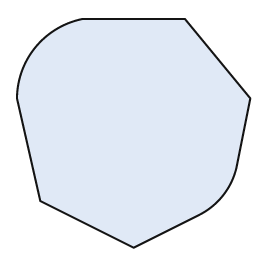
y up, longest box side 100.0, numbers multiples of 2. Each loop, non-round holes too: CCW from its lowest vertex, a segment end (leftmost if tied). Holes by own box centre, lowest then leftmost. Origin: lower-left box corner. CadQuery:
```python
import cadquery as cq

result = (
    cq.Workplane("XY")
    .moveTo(50.0, 0.0)
    .lineTo(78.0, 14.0)
    .threePointArc((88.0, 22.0), (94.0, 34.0))
    .lineTo(100.0, 64.0)
    .lineTo(72.0, 98.0)
    .lineTo(28.0, 98.0)
    .threePointArc((8.0, 86.0), (0.0, 64.0))
    .lineTo(10.0, 20.0)
    .close()
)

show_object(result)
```